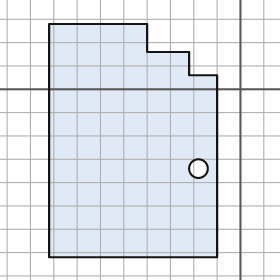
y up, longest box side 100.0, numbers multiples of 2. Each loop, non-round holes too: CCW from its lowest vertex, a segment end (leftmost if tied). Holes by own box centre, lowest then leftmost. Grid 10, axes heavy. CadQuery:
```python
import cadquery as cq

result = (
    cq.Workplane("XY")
    .moveTo(-82.0, -72.0)
    .lineTo(-10.0, -72.0)
    .lineTo(-10.0, 6.0)
    .lineTo(-22.0, 6.0)
    .lineTo(-22.0, 16.0)
    .lineTo(-40.0, 16.0)
    .lineTo(-40.0, 28.0)
    .lineTo(-82.0, 28.0)
    .close()
    .moveTo(-18.0, -34.0)
    .circle(4.0)
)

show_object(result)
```